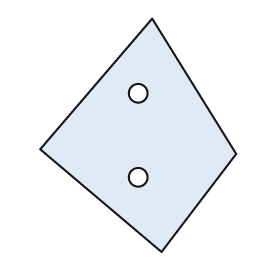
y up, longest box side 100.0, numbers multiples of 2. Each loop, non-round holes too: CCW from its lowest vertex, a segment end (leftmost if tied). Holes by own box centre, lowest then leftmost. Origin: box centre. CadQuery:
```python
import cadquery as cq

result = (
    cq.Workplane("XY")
    .moveTo(10.0, -50.0)
    .lineTo(42.0, -8.0)
    .lineTo(6.0, 50.0)
    .lineTo(-42.0, -6.0)
    .close()
    .moveTo(0.0, -18.0)
    .circle(4.0)
    .moveTo(0.0, 18.0)
    .circle(4.0)
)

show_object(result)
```